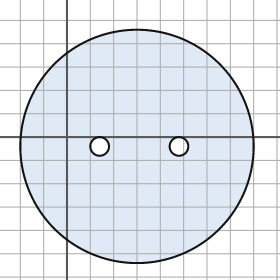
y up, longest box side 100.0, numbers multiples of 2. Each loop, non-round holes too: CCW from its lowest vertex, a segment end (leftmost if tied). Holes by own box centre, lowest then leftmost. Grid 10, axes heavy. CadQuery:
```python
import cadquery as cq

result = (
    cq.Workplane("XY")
    .moveTo(30.0, -4.0)
    .circle(50.0)
    .moveTo(14.0, -4.0)
    .circle(4.0)
    .moveTo(48.0, -4.0)
    .circle(4.0)
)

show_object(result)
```